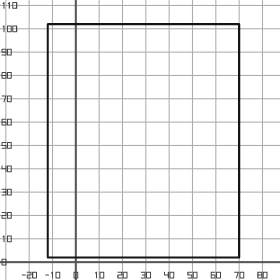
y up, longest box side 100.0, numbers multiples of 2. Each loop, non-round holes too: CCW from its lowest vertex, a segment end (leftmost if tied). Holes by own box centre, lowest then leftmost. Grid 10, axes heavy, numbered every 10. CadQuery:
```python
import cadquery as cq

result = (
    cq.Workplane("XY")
    .moveTo(-12.0, 2.0)
    .lineTo(70.0, 2.0)
    .lineTo(70.0, 102.0)
    .lineTo(-12.0, 102.0)
    .close()
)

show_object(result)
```